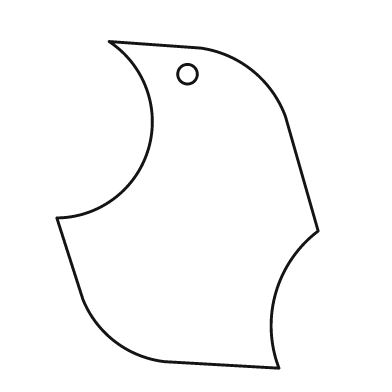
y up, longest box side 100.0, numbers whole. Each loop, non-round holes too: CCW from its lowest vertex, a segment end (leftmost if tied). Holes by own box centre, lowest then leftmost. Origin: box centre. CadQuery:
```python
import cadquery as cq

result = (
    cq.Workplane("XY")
    .moveTo(28.0, -50.0)
    .threePointArc((27.0, -27.0), (40.0, -8.0))
    .lineTo(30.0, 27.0)
    .threePointArc((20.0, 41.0), (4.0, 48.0))
    .lineTo(-24.0, 50.0)
    .threePointArc((-12.0, 17.0), (-40.0, -4.0))
    .lineTo(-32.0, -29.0)
    .threePointArc((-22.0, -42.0), (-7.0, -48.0))
    .close()
    .moveTo(0.0, 40.0)
    .circle(3.0)
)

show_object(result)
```